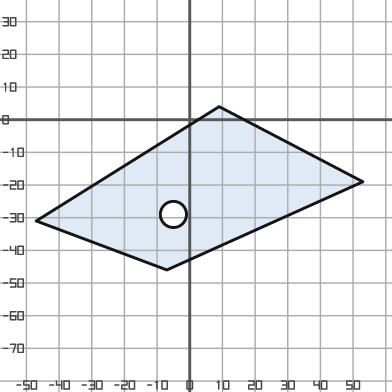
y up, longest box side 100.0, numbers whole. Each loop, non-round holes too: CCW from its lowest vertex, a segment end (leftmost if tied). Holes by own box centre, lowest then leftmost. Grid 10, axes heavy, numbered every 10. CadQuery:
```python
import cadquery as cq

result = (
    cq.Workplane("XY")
    .moveTo(-7.0, -46.0)
    .lineTo(53.0, -19.0)
    .lineTo(9.0, 4.0)
    .lineTo(-47.0, -31.0)
    .close()
    .moveTo(-5.0, -29.0)
    .circle(4.0)
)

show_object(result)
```